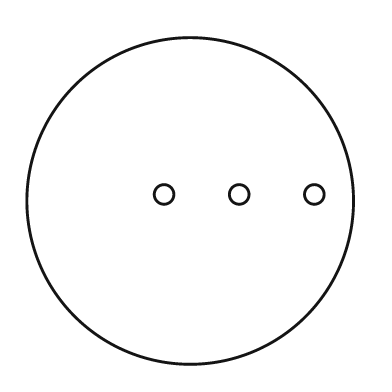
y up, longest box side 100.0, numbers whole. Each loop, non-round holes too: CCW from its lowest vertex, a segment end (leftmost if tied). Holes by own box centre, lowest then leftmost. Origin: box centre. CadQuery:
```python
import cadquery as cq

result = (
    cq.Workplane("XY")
    .moveTo(0.0, 0.0)
    .circle(50.0)
    .moveTo(-8.0, 2.0)
    .circle(3.0)
    .moveTo(15.0, 2.0)
    .circle(3.0)
    .moveTo(38.0, 2.0)
    .circle(3.0)
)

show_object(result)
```